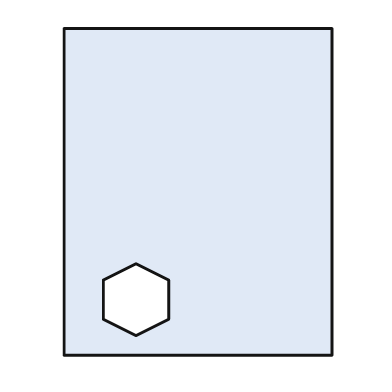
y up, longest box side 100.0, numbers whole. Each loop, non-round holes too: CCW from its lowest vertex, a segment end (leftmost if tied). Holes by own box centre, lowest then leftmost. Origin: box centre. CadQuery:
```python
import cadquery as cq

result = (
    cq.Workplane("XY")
    .moveTo(-41.0, -50.0)
    .lineTo(41.0, -50.0)
    .lineTo(41.0, 50.0)
    .lineTo(-41.0, 50.0)
    .close()
    .moveTo(-19.0, -44.0)
    .lineTo(-9.0, -39.0)
    .lineTo(-9.0, -27.0)
    .lineTo(-19.0, -22.0)
    .lineTo(-29.0, -27.0)
    .lineTo(-29.0, -39.0)
    .close()
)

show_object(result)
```